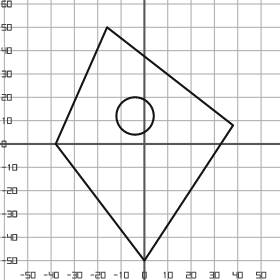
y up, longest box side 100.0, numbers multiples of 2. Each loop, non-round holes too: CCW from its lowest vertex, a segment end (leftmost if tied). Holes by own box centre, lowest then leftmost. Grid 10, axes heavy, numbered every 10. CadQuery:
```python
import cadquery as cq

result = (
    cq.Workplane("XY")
    .moveTo(0.0, -50.0)
    .lineTo(38.0, 8.0)
    .lineTo(-16.0, 50.0)
    .lineTo(-38.0, 0.0)
    .close()
    .moveTo(-4.0, 12.0)
    .circle(8.0)
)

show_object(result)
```